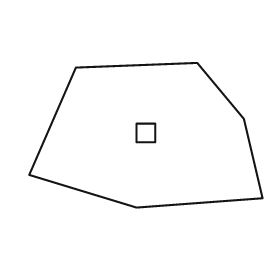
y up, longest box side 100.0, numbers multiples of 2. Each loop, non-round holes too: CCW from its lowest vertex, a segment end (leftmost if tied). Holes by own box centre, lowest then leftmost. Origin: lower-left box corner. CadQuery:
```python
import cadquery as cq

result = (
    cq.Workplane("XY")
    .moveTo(46.0, 0.0)
    .lineTo(100.0, 4.0)
    .lineTo(92.0, 38.0)
    .lineTo(72.0, 62.0)
    .lineTo(20.0, 60.0)
    .lineTo(0.0, 14.0)
    .close()
    .moveTo(46.0, 28.0)
    .lineTo(54.0, 28.0)
    .lineTo(54.0, 36.0)
    .lineTo(46.0, 36.0)
    .close()
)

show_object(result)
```